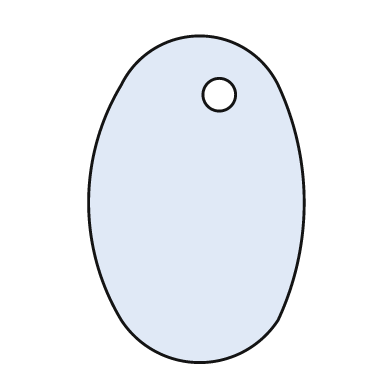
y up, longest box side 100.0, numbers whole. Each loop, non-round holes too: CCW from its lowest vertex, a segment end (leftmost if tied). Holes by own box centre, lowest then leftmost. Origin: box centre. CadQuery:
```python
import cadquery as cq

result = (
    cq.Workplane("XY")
    .moveTo(-23.0, -37.0)
    .threePointArc((1.0, -50.0), (25.0, -37.0))
    .threePointArc((33.0, -1.0), (25.0, 35.0))
    .threePointArc((1.0, 50.0), (-23.0, 35.0))
    .threePointArc((-33.0, -1.0), (-23.0, -37.0))
    .close()
    .moveTo(7.0, 32.0)
    .circle(5.0)
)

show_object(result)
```